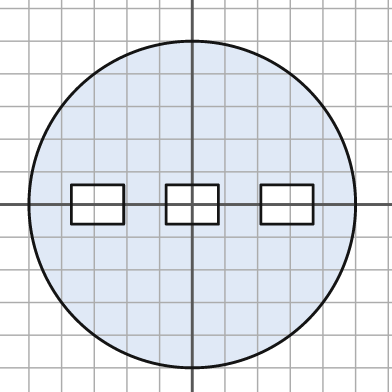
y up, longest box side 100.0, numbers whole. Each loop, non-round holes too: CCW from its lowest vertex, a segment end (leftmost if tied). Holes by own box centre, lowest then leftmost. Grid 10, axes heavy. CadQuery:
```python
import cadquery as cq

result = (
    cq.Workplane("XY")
    .moveTo(0.0, 0.0)
    .circle(50.0)
    .moveTo(-37.0, -6.0)
    .lineTo(-21.0, -6.0)
    .lineTo(-21.0, 6.0)
    .lineTo(-37.0, 6.0)
    .close()
    .moveTo(-8.0, -6.0)
    .lineTo(8.0, -6.0)
    .lineTo(8.0, 6.0)
    .lineTo(-8.0, 6.0)
    .close()
    .moveTo(21.0, -6.0)
    .lineTo(37.0, -6.0)
    .lineTo(37.0, 6.0)
    .lineTo(21.0, 6.0)
    .close()
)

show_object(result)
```